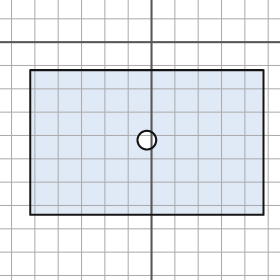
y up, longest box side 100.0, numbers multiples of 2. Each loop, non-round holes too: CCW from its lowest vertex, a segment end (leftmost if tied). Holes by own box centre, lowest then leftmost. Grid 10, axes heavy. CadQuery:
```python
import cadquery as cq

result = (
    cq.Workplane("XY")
    .moveTo(-52.0, -74.0)
    .lineTo(48.0, -74.0)
    .lineTo(48.0, -12.0)
    .lineTo(-52.0, -12.0)
    .close()
    .moveTo(-2.0, -42.0)
    .circle(4.0)
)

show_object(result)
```